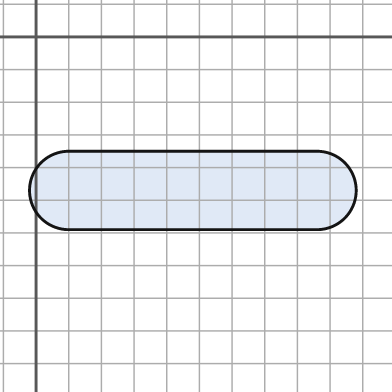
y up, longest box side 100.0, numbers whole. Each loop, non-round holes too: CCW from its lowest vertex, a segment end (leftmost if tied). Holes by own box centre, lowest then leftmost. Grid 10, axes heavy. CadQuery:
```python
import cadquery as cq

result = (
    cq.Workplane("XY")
    .moveTo(10.0, -59.0)
    .lineTo(86.0, -59.0)
    .threePointArc((98.0, -47.0), (86.0, -35.0))
    .lineTo(10.0, -35.0)
    .threePointArc((-2.0, -47.0), (10.0, -59.0))
    .close()
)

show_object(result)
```